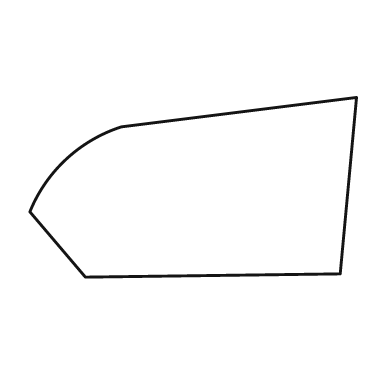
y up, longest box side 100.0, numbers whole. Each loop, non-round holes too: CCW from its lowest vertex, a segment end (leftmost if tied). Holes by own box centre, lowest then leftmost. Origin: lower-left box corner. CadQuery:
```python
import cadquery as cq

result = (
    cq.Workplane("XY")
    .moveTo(17.0, 0.0)
    .lineTo(95.0, 1.0)
    .lineTo(100.0, 55.0)
    .lineTo(28.0, 46.0)
    .threePointArc((11.0, 36.0), (0.0, 20.0))
    .close()
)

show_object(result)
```